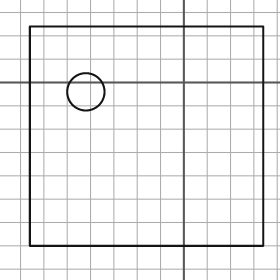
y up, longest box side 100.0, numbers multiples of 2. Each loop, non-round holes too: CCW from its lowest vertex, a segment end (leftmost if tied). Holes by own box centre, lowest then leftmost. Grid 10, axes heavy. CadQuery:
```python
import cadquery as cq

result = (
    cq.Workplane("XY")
    .moveTo(-66.0, -70.0)
    .lineTo(34.0, -70.0)
    .lineTo(34.0, 24.0)
    .lineTo(-66.0, 24.0)
    .close()
    .moveTo(-42.0, -4.0)
    .circle(8.0)
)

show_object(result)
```